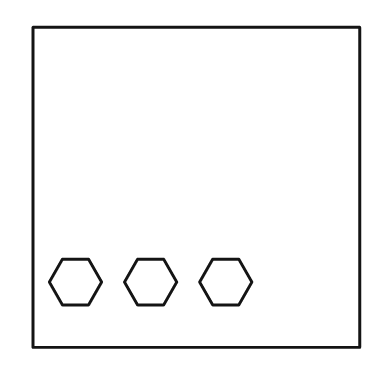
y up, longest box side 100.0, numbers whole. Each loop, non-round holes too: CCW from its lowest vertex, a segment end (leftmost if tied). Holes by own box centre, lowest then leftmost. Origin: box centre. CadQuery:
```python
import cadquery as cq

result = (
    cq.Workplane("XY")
    .moveTo(-50.0, -49.0)
    .lineTo(50.0, -49.0)
    .lineTo(50.0, 49.0)
    .lineTo(-50.0, 49.0)
    .close()
    .moveTo(-41.0, -36.0)
    .lineTo(-33.0, -36.0)
    .lineTo(-29.0, -29.0)
    .lineTo(-33.0, -22.0)
    .lineTo(-41.0, -22.0)
    .lineTo(-45.0, -29.0)
    .close()
    .moveTo(-18.0, -36.0)
    .lineTo(-10.0, -36.0)
    .lineTo(-6.0, -29.0)
    .lineTo(-10.0, -22.0)
    .lineTo(-18.0, -22.0)
    .lineTo(-22.0, -29.0)
    .close()
    .moveTo(5.0, -36.0)
    .lineTo(13.0, -36.0)
    .lineTo(17.0, -29.0)
    .lineTo(13.0, -22.0)
    .lineTo(5.0, -22.0)
    .lineTo(1.0, -29.0)
    .close()
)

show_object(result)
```